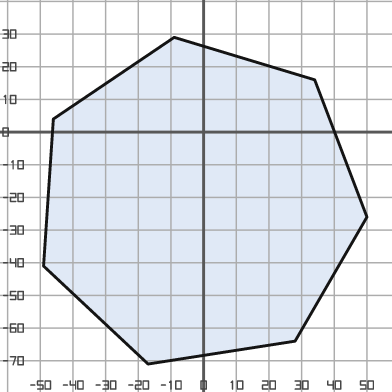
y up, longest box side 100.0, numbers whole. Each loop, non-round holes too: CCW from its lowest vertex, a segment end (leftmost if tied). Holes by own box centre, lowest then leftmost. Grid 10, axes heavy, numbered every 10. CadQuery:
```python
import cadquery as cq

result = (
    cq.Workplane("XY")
    .moveTo(-17.0, -71.0)
    .lineTo(28.0, -64.0)
    .lineTo(50.0, -26.0)
    .lineTo(34.0, 16.0)
    .lineTo(-9.0, 29.0)
    .lineTo(-46.0, 4.0)
    .lineTo(-49.0, -41.0)
    .close()
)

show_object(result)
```